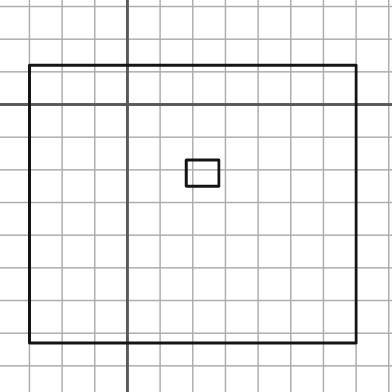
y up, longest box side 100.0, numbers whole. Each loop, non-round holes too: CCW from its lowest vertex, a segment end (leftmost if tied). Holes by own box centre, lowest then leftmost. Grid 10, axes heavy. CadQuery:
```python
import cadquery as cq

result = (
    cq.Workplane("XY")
    .moveTo(-30.0, -73.0)
    .lineTo(70.0, -73.0)
    .lineTo(70.0, 12.0)
    .lineTo(-30.0, 12.0)
    .close()
    .moveTo(18.0, -25.0)
    .lineTo(28.0, -25.0)
    .lineTo(28.0, -17.0)
    .lineTo(18.0, -17.0)
    .close()
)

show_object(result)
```